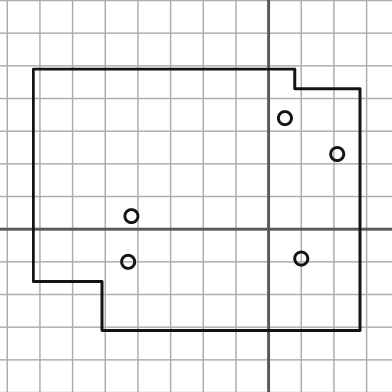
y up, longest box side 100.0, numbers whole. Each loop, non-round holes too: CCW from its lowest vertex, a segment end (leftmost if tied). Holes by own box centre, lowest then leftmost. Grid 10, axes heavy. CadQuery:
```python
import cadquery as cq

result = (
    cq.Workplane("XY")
    .moveTo(-51.0, -31.0)
    .lineTo(28.0, -31.0)
    .lineTo(28.0, 43.0)
    .lineTo(8.0, 43.0)
    .lineTo(8.0, 49.0)
    .lineTo(-72.0, 49.0)
    .lineTo(-72.0, -16.0)
    .lineTo(-51.0, -16.0)
    .close()
    .moveTo(-43.0, -10.0)
    .circle(2.0)
    .moveTo(10.0, -9.0)
    .circle(2.0)
    .moveTo(-42.0, 4.0)
    .circle(2.0)
    .moveTo(21.0, 23.0)
    .circle(2.0)
    .moveTo(5.0, 34.0)
    .circle(2.0)
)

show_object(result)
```